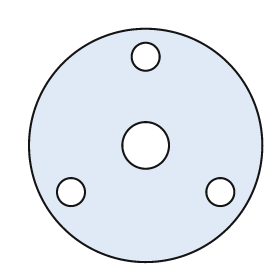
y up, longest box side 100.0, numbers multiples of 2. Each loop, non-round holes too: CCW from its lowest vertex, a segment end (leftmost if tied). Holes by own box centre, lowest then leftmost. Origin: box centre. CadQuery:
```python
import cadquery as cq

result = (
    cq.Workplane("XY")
    .moveTo(0.0, 0.0)
    .circle(50.0)
    .moveTo(-32.0, -20.0)
    .circle(6.0)
    .moveTo(32.0, -20.0)
    .circle(6.0)
    .moveTo(0.0, 0.0)
    .circle(10.0)
    .moveTo(0.0, 38.0)
    .circle(6.0)
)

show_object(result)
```